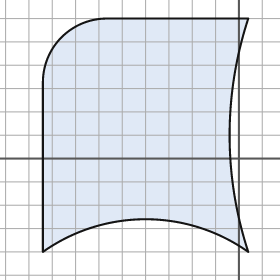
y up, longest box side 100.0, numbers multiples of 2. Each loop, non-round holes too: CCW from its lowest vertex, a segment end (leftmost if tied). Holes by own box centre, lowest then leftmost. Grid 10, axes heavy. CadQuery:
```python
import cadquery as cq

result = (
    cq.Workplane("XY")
    .moveTo(-84.0, -40.0)
    .threePointArc((-40.0, -26.0), (4.0, -40.0))
    .threePointArc((-4.0, 10.0), (4.0, 60.0))
    .lineTo(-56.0, 60.0)
    .threePointArc((-76.0, 52.0), (-84.0, 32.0))
    .close()
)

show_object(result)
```